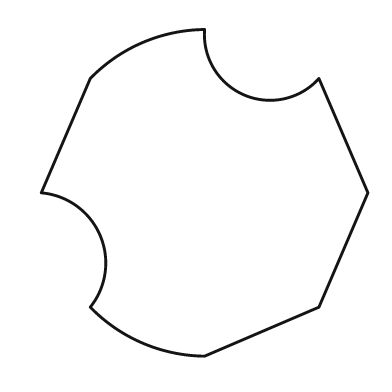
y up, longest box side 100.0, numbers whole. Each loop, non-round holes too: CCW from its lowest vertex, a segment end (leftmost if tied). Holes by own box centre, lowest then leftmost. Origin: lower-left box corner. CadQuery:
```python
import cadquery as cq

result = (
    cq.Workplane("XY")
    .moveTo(50.0, 0.0)
    .lineTo(85.0, 15.0)
    .lineTo(100.0, 50.0)
    .lineTo(85.0, 85.0)
    .threePointArc((62.0, 80.0), (50.0, 100.0))
    .threePointArc((31.0, 96.0), (15.0, 85.0))
    .lineTo(0.0, 50.0)
    .threePointArc((18.0, 37.0), (15.0, 15.0))
    .threePointArc((31.0, 4.0), (50.0, 0.0))
    .close()
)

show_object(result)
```